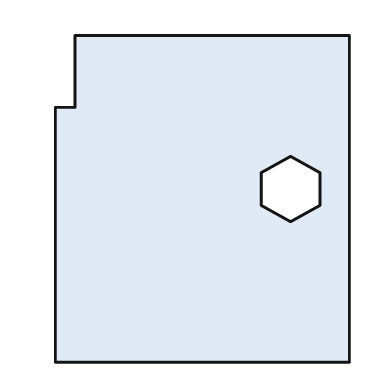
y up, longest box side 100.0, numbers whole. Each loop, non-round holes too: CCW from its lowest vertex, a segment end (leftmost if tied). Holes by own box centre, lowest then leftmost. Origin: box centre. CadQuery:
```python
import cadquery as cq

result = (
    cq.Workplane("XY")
    .moveTo(-45.0, -50.0)
    .lineTo(45.0, -50.0)
    .lineTo(45.0, 50.0)
    .lineTo(-39.0, 50.0)
    .lineTo(-39.0, 28.0)
    .lineTo(-45.0, 28.0)
    .close()
    .moveTo(27.0, -7.0)
    .lineTo(36.0, -2.0)
    .lineTo(36.0, 8.0)
    .lineTo(27.0, 13.0)
    .lineTo(18.0, 8.0)
    .lineTo(18.0, -2.0)
    .close()
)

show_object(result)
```